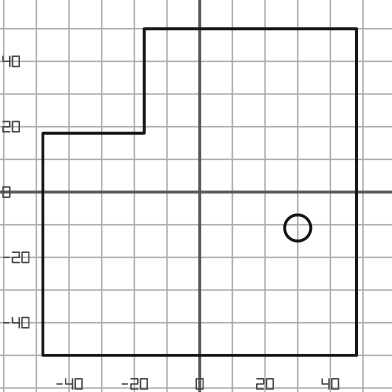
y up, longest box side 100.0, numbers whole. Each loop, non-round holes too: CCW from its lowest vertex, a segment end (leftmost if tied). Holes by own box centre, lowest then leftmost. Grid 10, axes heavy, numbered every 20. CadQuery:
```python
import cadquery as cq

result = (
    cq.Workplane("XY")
    .moveTo(-48.0, -50.0)
    .lineTo(48.0, -50.0)
    .lineTo(48.0, 50.0)
    .lineTo(-17.0, 50.0)
    .lineTo(-17.0, 18.0)
    .lineTo(-48.0, 18.0)
    .close()
    .moveTo(30.0, -11.0)
    .circle(4.0)
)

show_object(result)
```